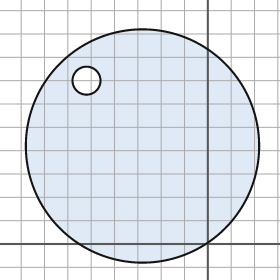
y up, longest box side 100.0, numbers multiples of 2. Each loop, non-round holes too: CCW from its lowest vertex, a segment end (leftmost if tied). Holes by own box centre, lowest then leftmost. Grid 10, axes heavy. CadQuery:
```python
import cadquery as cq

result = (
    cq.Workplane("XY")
    .moveTo(-28.0, 42.0)
    .circle(50.0)
    .moveTo(-52.0, 70.0)
    .circle(6.0)
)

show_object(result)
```